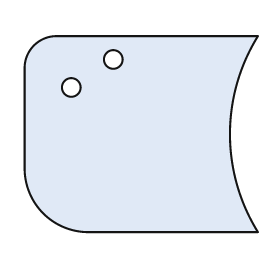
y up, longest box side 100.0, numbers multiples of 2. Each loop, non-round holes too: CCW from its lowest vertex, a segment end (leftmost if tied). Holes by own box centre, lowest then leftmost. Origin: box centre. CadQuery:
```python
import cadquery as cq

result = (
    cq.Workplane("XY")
    .moveTo(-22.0, -42.0)
    .lineTo(50.0, -42.0)
    .threePointArc((38.0, 0.0), (50.0, 42.0))
    .lineTo(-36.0, 42.0)
    .threePointArc((-46.0, 38.0), (-50.0, 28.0))
    .lineTo(-50.0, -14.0)
    .threePointArc((-42.0, -34.0), (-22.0, -42.0))
    .close()
    .moveTo(-30.0, 20.0)
    .circle(4.0)
    .moveTo(-12.0, 32.0)
    .circle(4.0)
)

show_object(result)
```